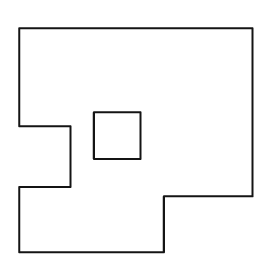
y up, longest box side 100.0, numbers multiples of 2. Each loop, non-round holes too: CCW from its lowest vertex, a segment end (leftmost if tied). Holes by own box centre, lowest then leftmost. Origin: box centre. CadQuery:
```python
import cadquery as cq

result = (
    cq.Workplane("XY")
    .moveTo(-50.0, -48.0)
    .lineTo(12.0, -48.0)
    .lineTo(12.0, -24.0)
    .lineTo(50.0, -24.0)
    .lineTo(50.0, 48.0)
    .lineTo(-50.0, 48.0)
    .lineTo(-50.0, 6.0)
    .lineTo(-28.0, 6.0)
    .lineTo(-28.0, -20.0)
    .lineTo(-50.0, -20.0)
    .close()
    .moveTo(-18.0, -8.0)
    .lineTo(2.0, -8.0)
    .lineTo(2.0, 12.0)
    .lineTo(-18.0, 12.0)
    .close()
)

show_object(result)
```